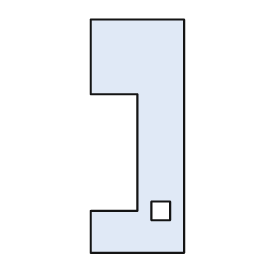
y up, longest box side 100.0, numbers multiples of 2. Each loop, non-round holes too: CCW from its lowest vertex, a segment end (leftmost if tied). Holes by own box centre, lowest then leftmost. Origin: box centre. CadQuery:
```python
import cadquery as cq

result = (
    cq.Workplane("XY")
    .moveTo(-20.0, -50.0)
    .lineTo(20.0, -50.0)
    .lineTo(20.0, 50.0)
    .lineTo(-20.0, 50.0)
    .lineTo(-20.0, 18.0)
    .lineTo(0.0, 18.0)
    .lineTo(0.0, -32.0)
    .lineTo(-20.0, -32.0)
    .close()
    .moveTo(6.0, -36.0)
    .lineTo(14.0, -36.0)
    .lineTo(14.0, -28.0)
    .lineTo(6.0, -28.0)
    .close()
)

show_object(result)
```